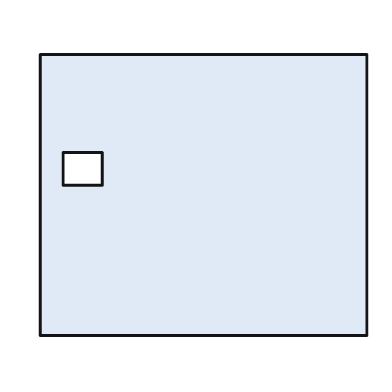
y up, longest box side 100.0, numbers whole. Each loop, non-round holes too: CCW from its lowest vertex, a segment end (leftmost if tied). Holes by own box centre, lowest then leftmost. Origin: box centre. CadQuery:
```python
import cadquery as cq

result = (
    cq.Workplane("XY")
    .moveTo(-50.0, -43.0)
    .lineTo(50.0, -43.0)
    .lineTo(50.0, 43.0)
    .lineTo(-50.0, 43.0)
    .close()
    .moveTo(-43.0, 3.0)
    .lineTo(-31.0, 3.0)
    .lineTo(-31.0, 13.0)
    .lineTo(-43.0, 13.0)
    .close()
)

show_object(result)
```